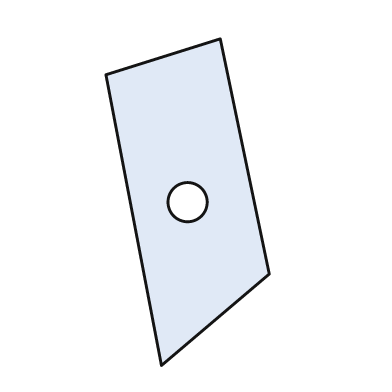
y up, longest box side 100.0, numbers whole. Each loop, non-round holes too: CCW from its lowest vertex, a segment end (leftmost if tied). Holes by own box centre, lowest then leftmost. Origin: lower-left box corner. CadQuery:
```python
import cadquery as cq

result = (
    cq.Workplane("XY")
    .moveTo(17.0, 0.0)
    .lineTo(50.0, 28.0)
    .lineTo(35.0, 100.0)
    .lineTo(0.0, 89.0)
    .close()
    .moveTo(25.0, 50.0)
    .circle(6.0)
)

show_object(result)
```